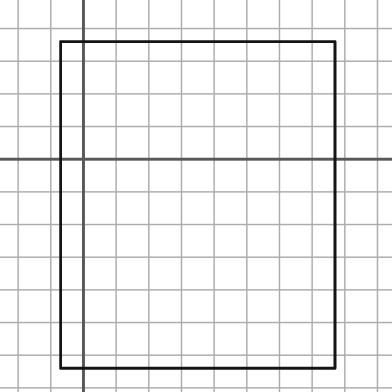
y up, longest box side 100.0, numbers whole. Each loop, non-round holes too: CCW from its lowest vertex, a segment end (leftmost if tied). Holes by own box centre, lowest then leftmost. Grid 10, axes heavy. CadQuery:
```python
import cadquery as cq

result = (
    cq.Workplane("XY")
    .moveTo(-7.0, -64.0)
    .lineTo(77.0, -64.0)
    .lineTo(77.0, 36.0)
    .lineTo(-7.0, 36.0)
    .close()
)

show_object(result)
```